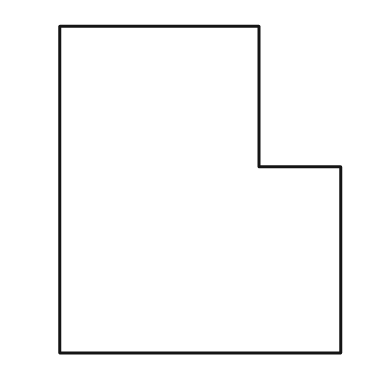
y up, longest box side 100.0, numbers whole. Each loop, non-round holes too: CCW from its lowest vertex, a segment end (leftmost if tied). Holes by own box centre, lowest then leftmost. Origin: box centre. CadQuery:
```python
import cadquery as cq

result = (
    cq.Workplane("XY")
    .moveTo(-43.0, -50.0)
    .lineTo(43.0, -50.0)
    .lineTo(43.0, 7.0)
    .lineTo(18.0, 7.0)
    .lineTo(18.0, 50.0)
    .lineTo(-43.0, 50.0)
    .close()
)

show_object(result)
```